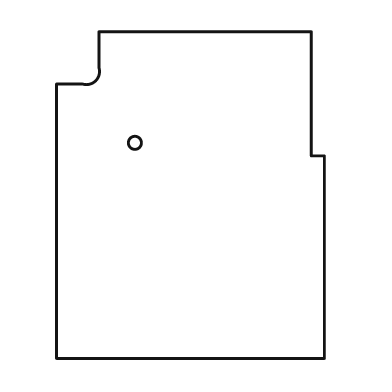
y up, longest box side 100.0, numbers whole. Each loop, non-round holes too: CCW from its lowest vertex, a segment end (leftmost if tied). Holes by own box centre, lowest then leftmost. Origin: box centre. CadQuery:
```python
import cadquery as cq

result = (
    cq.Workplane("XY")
    .moveTo(-41.0, -50.0)
    .lineTo(41.0, -50.0)
    .lineTo(41.0, 12.0)
    .lineTo(37.0, 12.0)
    .lineTo(37.0, 50.0)
    .lineTo(-28.0, 50.0)
    .lineTo(-28.0, 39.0)
    .threePointArc((-29.0, 35.0), (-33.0, 34.0))
    .lineTo(-41.0, 34.0)
    .close()
    .moveTo(-17.0, 16.0)
    .circle(2.0)
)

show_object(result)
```